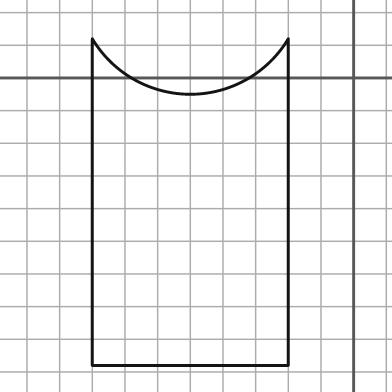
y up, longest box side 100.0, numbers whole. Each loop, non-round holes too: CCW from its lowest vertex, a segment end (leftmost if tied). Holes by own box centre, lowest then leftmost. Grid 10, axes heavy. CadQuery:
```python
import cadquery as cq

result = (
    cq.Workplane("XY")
    .moveTo(-80.0, -88.0)
    .lineTo(-20.0, -88.0)
    .lineTo(-20.0, 12.0)
    .threePointArc((-50.0, -5.0), (-80.0, 12.0))
    .close()
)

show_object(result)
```